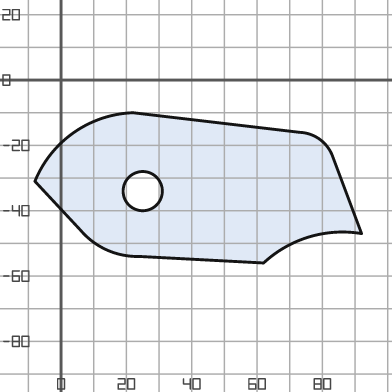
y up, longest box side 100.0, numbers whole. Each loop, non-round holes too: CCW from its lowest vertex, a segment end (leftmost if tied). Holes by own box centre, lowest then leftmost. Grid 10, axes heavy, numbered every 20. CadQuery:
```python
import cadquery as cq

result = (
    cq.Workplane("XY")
    .moveTo(62.0, -56.0)
    .threePointArc((76.0, -48.0), (92.0, -47.0))
    .lineTo(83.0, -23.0)
    .threePointArc((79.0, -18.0), (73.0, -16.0))
    .lineTo(22.0, -10.0)
    .threePointArc((4.0, -16.0), (-8.0, -31.0))
    .lineTo(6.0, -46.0)
    .threePointArc((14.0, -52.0), (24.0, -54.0))
    .close()
    .moveTo(25.0, -34.0)
    .circle(6.0)
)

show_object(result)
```